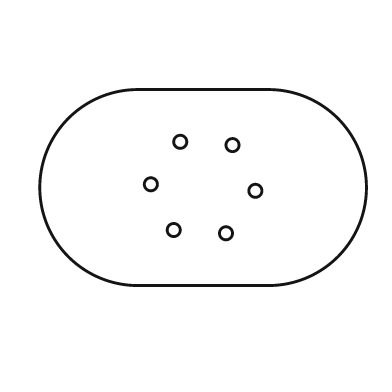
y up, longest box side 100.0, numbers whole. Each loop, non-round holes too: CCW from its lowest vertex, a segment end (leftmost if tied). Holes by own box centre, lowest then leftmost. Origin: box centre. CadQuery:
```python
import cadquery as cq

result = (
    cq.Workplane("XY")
    .moveTo(-20.0, -30.0)
    .lineTo(20.0, -30.0)
    .threePointArc((50.0, 0.0), (20.0, 30.0))
    .lineTo(-20.0, 30.0)
    .threePointArc((-50.0, 0.0), (-20.0, -30.0))
    .close()
    .moveTo(7.0, -14.0)
    .circle(2.0)
    .moveTo(-9.0, -13.0)
    .circle(2.0)
    .moveTo(16.0, -1.0)
    .circle(2.0)
    .moveTo(-16.0, 1.0)
    .circle(2.0)
    .moveTo(9.0, 13.0)
    .circle(2.0)
    .moveTo(-7.0, 14.0)
    .circle(2.0)
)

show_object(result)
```